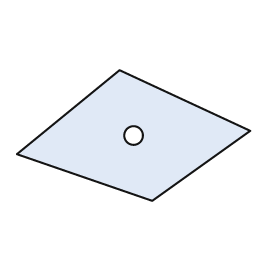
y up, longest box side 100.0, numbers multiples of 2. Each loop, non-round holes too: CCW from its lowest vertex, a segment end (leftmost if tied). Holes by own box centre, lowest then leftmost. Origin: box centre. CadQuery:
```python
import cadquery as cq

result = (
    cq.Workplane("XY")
    .moveTo(8.0, -28.0)
    .lineTo(50.0, 2.0)
    .lineTo(-6.0, 28.0)
    .lineTo(-50.0, -8.0)
    .close()
    .moveTo(0.0, 0.0)
    .circle(4.0)
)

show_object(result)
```